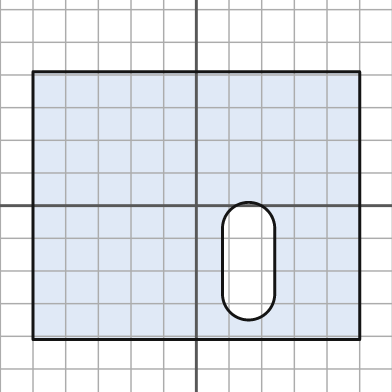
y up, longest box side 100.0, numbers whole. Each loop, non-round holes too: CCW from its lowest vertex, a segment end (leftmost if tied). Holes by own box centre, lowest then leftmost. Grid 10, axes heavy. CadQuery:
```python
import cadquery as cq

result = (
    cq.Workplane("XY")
    .moveTo(-50.0, -41.0)
    .lineTo(50.0, -41.0)
    .lineTo(50.0, 41.0)
    .lineTo(-50.0, 41.0)
    .close()
    .moveTo(8.0, -27.0)
    .threePointArc((16.0, -35.0), (24.0, -27.0))
    .lineTo(24.0, -7.0)
    .threePointArc((16.0, 1.0), (8.0, -7.0))
    .close()
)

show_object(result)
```